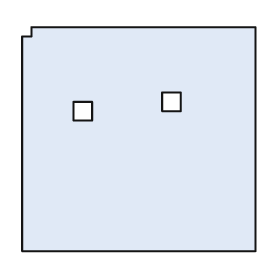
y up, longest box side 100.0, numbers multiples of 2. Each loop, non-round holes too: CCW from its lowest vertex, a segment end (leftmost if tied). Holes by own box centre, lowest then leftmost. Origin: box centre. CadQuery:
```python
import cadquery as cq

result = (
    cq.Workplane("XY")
    .moveTo(-50.0, -48.0)
    .lineTo(50.0, -48.0)
    .lineTo(50.0, 48.0)
    .lineTo(-46.0, 48.0)
    .lineTo(-46.0, 44.0)
    .lineTo(-50.0, 44.0)
    .close()
    .moveTo(-28.0, 8.0)
    .lineTo(-20.0, 8.0)
    .lineTo(-20.0, 16.0)
    .lineTo(-28.0, 16.0)
    .close()
    .moveTo(10.0, 12.0)
    .lineTo(18.0, 12.0)
    .lineTo(18.0, 20.0)
    .lineTo(10.0, 20.0)
    .close()
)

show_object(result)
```